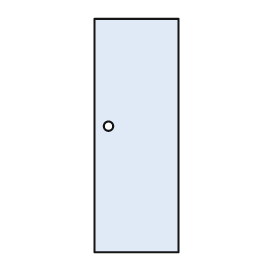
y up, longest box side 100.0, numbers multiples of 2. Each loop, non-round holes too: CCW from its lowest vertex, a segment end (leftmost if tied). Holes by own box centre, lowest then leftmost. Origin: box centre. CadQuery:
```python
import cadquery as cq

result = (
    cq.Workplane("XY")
    .moveTo(-18.0, -50.0)
    .lineTo(18.0, -50.0)
    .lineTo(18.0, 50.0)
    .lineTo(-18.0, 50.0)
    .close()
    .moveTo(-12.0, 4.0)
    .circle(2.0)
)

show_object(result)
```